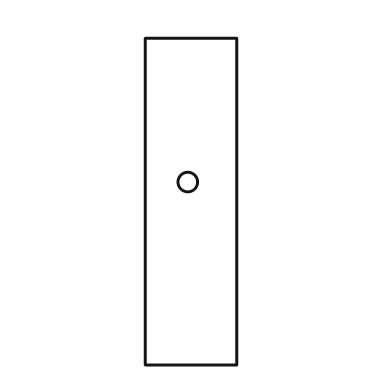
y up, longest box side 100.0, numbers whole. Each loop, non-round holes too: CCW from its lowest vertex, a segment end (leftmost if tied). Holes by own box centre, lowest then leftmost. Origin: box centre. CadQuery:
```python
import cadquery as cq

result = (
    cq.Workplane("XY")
    .moveTo(-14.0, -50.0)
    .lineTo(14.0, -50.0)
    .lineTo(14.0, 50.0)
    .lineTo(-14.0, 50.0)
    .close()
    .moveTo(-1.0, 6.0)
    .circle(3.0)
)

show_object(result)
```